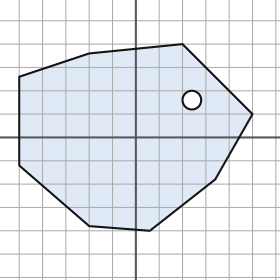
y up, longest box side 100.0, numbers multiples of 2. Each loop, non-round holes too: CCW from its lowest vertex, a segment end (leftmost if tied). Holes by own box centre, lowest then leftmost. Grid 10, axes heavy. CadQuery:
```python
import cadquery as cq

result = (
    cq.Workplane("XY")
    .moveTo(6.0, -40.0)
    .lineTo(34.0, -18.0)
    .lineTo(50.0, 10.0)
    .lineTo(20.0, 40.0)
    .lineTo(-20.0, 36.0)
    .lineTo(-50.0, 26.0)
    .lineTo(-50.0, -12.0)
    .lineTo(-20.0, -38.0)
    .close()
    .moveTo(24.0, 16.0)
    .circle(4.0)
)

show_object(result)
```